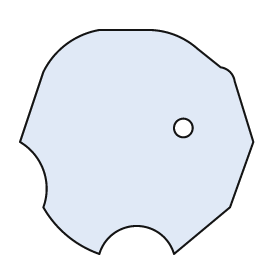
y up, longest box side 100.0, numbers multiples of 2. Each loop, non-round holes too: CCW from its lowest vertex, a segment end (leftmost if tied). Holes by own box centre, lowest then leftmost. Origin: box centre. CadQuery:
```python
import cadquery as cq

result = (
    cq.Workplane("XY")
    .moveTo(-16.0, -48.0)
    .threePointArc((0.0, -36.0), (16.0, -48.0))
    .lineTo(40.0, -28.0)
    .lineTo(50.0, 0.0)
    .lineTo(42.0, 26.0)
    .threePointArc((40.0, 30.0), (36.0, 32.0))
    .lineTo(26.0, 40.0)
    .threePointArc((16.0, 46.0), (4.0, 48.0))
    .lineTo(-16.0, 48.0)
    .threePointArc((-30.0, 42.0), (-40.0, 30.0))
    .lineTo(-50.0, 0.0)
    .threePointArc((-40.0, -12.0), (-40.0, -28.0))
    .threePointArc((-30.0, -40.0), (-16.0, -48.0))
    .close()
    .moveTo(20.0, 6.0)
    .circle(4.0)
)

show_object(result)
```